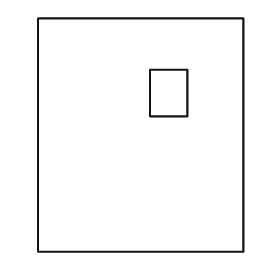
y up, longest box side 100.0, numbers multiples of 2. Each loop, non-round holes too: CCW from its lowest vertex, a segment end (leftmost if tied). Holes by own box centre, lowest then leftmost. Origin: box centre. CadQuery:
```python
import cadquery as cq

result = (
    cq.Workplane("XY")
    .moveTo(-44.0, -50.0)
    .lineTo(44.0, -50.0)
    .lineTo(44.0, 50.0)
    .lineTo(-44.0, 50.0)
    .close()
    .moveTo(4.0, 8.0)
    .lineTo(20.0, 8.0)
    .lineTo(20.0, 28.0)
    .lineTo(4.0, 28.0)
    .close()
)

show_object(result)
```